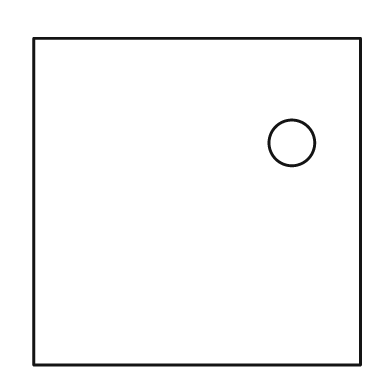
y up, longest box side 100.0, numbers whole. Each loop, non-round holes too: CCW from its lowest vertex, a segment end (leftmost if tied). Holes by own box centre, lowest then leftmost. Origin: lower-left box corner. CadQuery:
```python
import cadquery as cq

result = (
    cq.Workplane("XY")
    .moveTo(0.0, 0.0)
    .lineTo(100.0, 0.0)
    .lineTo(100.0, 100.0)
    .lineTo(0.0, 100.0)
    .close()
    .moveTo(79.0, 68.0)
    .circle(7.0)
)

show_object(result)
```